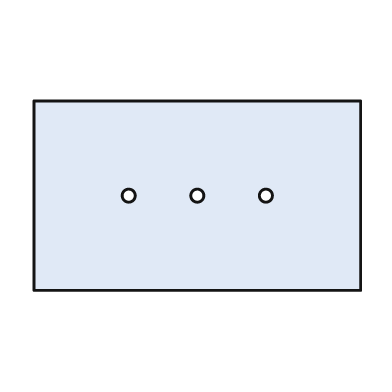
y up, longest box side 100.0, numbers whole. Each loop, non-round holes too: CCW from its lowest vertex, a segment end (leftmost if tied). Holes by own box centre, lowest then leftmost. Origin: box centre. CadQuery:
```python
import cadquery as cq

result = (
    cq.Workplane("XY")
    .moveTo(-50.0, -29.0)
    .lineTo(50.0, -29.0)
    .lineTo(50.0, 29.0)
    .lineTo(-50.0, 29.0)
    .close()
    .moveTo(-21.0, 0.0)
    .circle(2.0)
    .moveTo(0.0, 0.0)
    .circle(2.0)
    .moveTo(21.0, 0.0)
    .circle(2.0)
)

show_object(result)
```